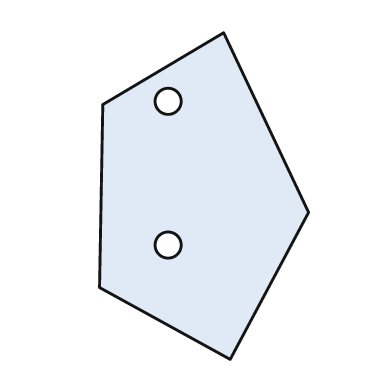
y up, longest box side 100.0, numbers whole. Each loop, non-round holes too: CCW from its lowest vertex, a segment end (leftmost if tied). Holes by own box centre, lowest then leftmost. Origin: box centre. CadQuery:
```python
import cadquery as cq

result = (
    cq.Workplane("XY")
    .moveTo(8.0, -50.0)
    .lineTo(32.0, -5.0)
    .lineTo(6.0, 50.0)
    .lineTo(-31.0, 28.0)
    .lineTo(-32.0, -28.0)
    .close()
    .moveTo(-11.0, -15.0)
    .circle(4.0)
    .moveTo(-11.0, 29.0)
    .circle(4.0)
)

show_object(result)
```